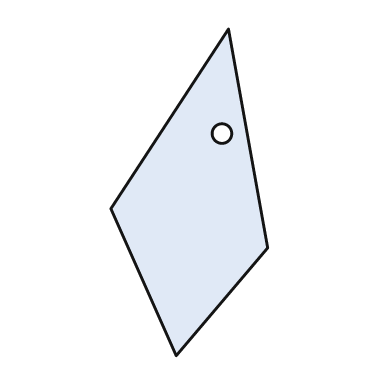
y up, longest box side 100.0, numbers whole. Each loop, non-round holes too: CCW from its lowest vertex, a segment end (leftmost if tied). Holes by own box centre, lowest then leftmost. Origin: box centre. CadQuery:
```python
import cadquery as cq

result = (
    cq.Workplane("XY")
    .moveTo(-4.0, -50.0)
    .lineTo(24.0, -17.0)
    .lineTo(12.0, 50.0)
    .lineTo(-24.0, -5.0)
    .close()
    .moveTo(10.0, 18.0)
    .circle(3.0)
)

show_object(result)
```